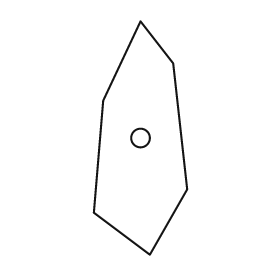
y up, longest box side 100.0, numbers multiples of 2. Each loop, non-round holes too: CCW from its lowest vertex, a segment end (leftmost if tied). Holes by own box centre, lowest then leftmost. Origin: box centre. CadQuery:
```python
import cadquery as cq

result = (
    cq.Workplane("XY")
    .moveTo(4.0, -50.0)
    .lineTo(20.0, -22.0)
    .lineTo(14.0, 32.0)
    .lineTo(0.0, 50.0)
    .lineTo(-16.0, 16.0)
    .lineTo(-20.0, -32.0)
    .close()
    .moveTo(0.0, 0.0)
    .circle(4.0)
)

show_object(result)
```